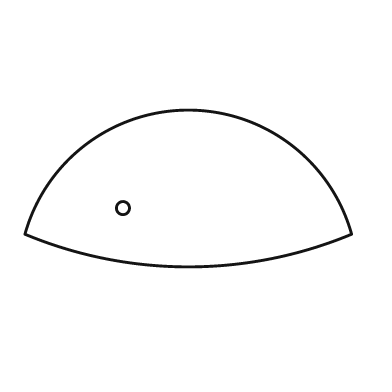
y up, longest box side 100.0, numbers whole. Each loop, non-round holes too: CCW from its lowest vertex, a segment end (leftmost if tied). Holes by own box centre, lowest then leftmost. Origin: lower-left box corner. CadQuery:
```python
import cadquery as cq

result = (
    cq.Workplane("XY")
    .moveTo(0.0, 10.0)
    .threePointArc((50.0, 0.0), (100.0, 10.0))
    .threePointArc((50.0, 48.0), (0.0, 10.0))
    .close()
    .moveTo(30.0, 18.0)
    .circle(2.0)
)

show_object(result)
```